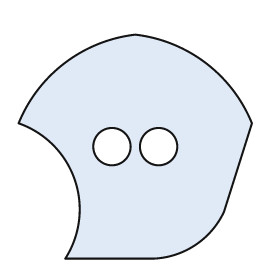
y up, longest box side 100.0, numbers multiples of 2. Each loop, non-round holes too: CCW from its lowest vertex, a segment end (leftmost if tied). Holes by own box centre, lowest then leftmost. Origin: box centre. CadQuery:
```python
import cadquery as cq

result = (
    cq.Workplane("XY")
    .moveTo(-30.0, -48.0)
    .lineTo(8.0, -48.0)
    .threePointArc((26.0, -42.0), (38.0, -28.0))
    .lineTo(50.0, 10.0)
    .threePointArc((30.0, 36.0), (0.0, 48.0))
    .threePointArc((-30.0, 36.0), (-50.0, 10.0))
    .threePointArc((-26.0, -14.0), (-30.0, -48.0))
    .close()
    .moveTo(-10.0, 0.0)
    .circle(8.0)
    .moveTo(10.0, 0.0)
    .circle(8.0)
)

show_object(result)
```